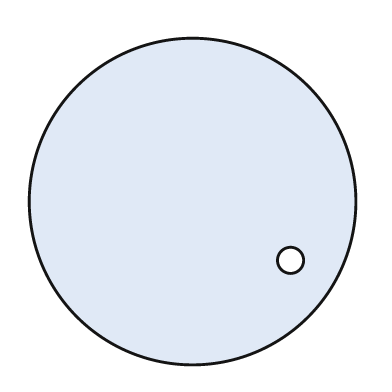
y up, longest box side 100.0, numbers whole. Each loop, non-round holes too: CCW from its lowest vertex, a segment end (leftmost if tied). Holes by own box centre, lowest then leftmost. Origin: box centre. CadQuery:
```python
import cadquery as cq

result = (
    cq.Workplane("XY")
    .moveTo(0.0, 0.0)
    .circle(50.0)
    .moveTo(30.0, -18.0)
    .circle(4.0)
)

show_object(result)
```